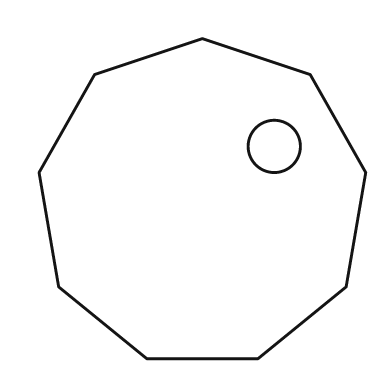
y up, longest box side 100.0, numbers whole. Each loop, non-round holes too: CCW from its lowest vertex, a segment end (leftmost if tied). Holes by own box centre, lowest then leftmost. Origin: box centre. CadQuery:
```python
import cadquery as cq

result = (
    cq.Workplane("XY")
    .moveTo(-17.0, -49.0)
    .lineTo(17.0, -49.0)
    .lineTo(44.0, -27.0)
    .lineTo(50.0, 8.0)
    .lineTo(33.0, 38.0)
    .lineTo(0.0, 49.0)
    .lineTo(-33.0, 38.0)
    .lineTo(-50.0, 8.0)
    .lineTo(-44.0, -27.0)
    .close()
    .moveTo(22.0, 16.0)
    .circle(8.0)
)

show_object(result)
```